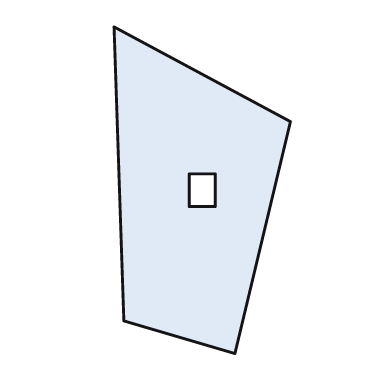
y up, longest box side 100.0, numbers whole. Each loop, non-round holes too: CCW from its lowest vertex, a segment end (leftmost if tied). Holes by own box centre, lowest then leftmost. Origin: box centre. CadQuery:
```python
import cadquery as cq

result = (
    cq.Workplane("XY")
    .moveTo(10.0, -50.0)
    .lineTo(27.0, 21.0)
    .lineTo(-27.0, 50.0)
    .lineTo(-24.0, -40.0)
    .close()
    .moveTo(-4.0, -5.0)
    .lineTo(4.0, -5.0)
    .lineTo(4.0, 5.0)
    .lineTo(-4.0, 5.0)
    .close()
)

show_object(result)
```